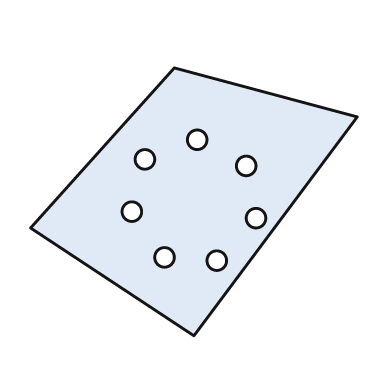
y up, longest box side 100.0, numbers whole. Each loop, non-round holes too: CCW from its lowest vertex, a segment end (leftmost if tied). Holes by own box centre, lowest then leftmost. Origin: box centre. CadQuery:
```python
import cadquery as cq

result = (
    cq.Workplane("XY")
    .moveTo(0.0, -41.0)
    .lineTo(50.0, 26.0)
    .lineTo(-6.0, 41.0)
    .lineTo(-50.0, -8.0)
    .close()
    .moveTo(7.0, -18.0)
    .circle(3.0)
    .moveTo(-9.0, -17.0)
    .circle(3.0)
    .moveTo(19.0, -5.0)
    .circle(3.0)
    .moveTo(-19.0, -3.0)
    .circle(3.0)
    .moveTo(16.0, 11.0)
    .circle(3.0)
    .moveTo(-15.0, 13.0)
    .circle(3.0)
    .moveTo(1.0, 19.0)
    .circle(3.0)
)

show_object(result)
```